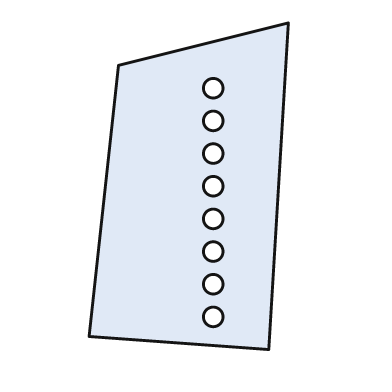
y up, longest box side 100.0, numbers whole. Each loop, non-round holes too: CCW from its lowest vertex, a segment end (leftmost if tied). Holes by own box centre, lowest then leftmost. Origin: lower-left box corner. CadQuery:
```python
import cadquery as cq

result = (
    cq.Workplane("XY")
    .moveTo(55.0, 0.0)
    .lineTo(61.0, 100.0)
    .lineTo(9.0, 87.0)
    .lineTo(0.0, 4.0)
    .close()
    .moveTo(38.0, 10.0)
    .circle(3.0)
    .moveTo(38.0, 20.0)
    .circle(3.0)
    .moveTo(38.0, 30.0)
    .circle(3.0)
    .moveTo(38.0, 40.0)
    .circle(3.0)
    .moveTo(38.0, 50.0)
    .circle(3.0)
    .moveTo(38.0, 60.0)
    .circle(3.0)
    .moveTo(38.0, 70.0)
    .circle(3.0)
    .moveTo(38.0, 80.0)
    .circle(3.0)
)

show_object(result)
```